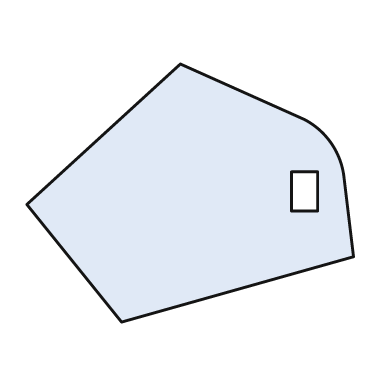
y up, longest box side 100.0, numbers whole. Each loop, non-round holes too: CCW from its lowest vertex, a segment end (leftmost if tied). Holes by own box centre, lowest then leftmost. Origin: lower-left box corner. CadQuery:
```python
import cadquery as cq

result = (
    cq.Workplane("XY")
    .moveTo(29.0, 0.0)
    .lineTo(100.0, 20.0)
    .lineTo(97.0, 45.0)
    .threePointArc((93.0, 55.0), (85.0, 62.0))
    .lineTo(47.0, 79.0)
    .lineTo(0.0, 36.0)
    .close()
    .moveTo(81.0, 34.0)
    .lineTo(89.0, 34.0)
    .lineTo(89.0, 46.0)
    .lineTo(81.0, 46.0)
    .close()
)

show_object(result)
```